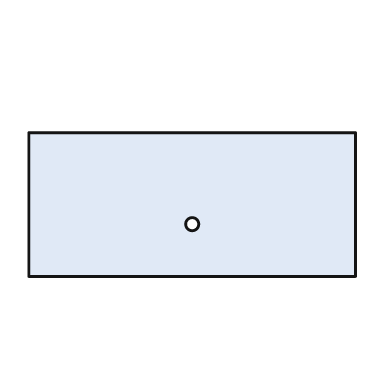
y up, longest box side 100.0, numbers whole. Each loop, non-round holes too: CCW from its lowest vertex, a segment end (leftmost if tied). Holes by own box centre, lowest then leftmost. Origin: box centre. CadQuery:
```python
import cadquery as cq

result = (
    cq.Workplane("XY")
    .moveTo(-50.0, -22.0)
    .lineTo(50.0, -22.0)
    .lineTo(50.0, 22.0)
    .lineTo(-50.0, 22.0)
    .close()
    .moveTo(0.0, -6.0)
    .circle(2.0)
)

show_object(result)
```